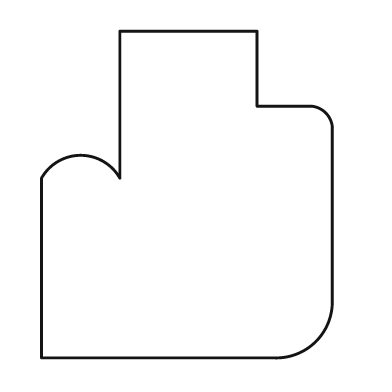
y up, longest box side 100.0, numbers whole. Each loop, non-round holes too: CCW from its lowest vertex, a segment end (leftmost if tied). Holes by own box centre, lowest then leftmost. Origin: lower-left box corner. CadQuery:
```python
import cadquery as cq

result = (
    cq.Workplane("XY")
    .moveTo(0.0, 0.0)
    .lineTo(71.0, 0.0)
    .threePointArc((84.0, 5.0), (89.0, 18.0))
    .lineTo(89.0, 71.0)
    .threePointArc((87.0, 75.0), (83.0, 77.0))
    .lineTo(66.0, 77.0)
    .lineTo(66.0, 100.0)
    .lineTo(24.0, 100.0)
    .lineTo(24.0, 55.0)
    .threePointArc((12.0, 62.0), (0.0, 55.0))
    .close()
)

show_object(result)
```